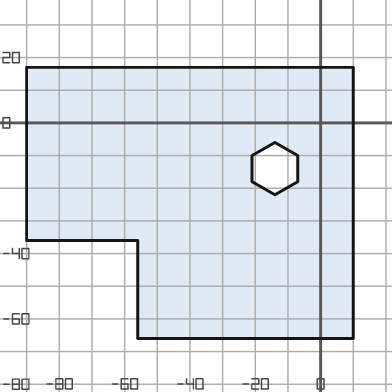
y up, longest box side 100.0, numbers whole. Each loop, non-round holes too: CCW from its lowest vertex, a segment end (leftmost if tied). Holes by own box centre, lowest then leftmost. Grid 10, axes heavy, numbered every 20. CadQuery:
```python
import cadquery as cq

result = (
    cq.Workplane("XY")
    .moveTo(-56.0, -66.0)
    .lineTo(10.0, -66.0)
    .lineTo(10.0, 17.0)
    .lineTo(-90.0, 17.0)
    .lineTo(-90.0, -36.0)
    .lineTo(-56.0, -36.0)
    .close()
    .moveTo(-14.0, -22.0)
    .lineTo(-7.0, -18.0)
    .lineTo(-7.0, -10.0)
    .lineTo(-14.0, -6.0)
    .lineTo(-21.0, -10.0)
    .lineTo(-21.0, -18.0)
    .close()
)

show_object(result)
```